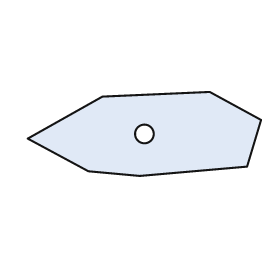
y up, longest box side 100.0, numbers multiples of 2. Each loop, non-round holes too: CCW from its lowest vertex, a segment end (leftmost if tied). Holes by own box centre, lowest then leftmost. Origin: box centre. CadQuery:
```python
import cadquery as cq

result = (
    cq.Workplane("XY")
    .moveTo(-2.0, -18.0)
    .lineTo(44.0, -14.0)
    .lineTo(50.0, 6.0)
    .lineTo(28.0, 18.0)
    .lineTo(-18.0, 16.0)
    .lineTo(-50.0, -2.0)
    .lineTo(-24.0, -16.0)
    .close()
    .moveTo(0.0, 0.0)
    .circle(4.0)
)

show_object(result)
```